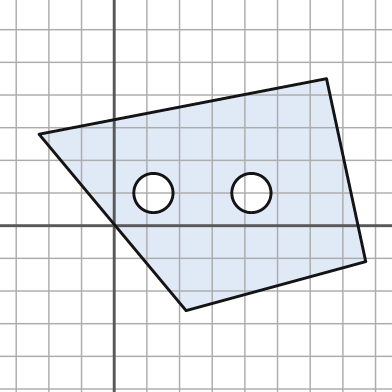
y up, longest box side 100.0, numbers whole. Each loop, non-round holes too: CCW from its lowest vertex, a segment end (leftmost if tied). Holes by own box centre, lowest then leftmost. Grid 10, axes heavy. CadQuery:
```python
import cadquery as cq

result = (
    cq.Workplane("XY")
    .moveTo(22.0, -26.0)
    .lineTo(77.0, -11.0)
    .lineTo(65.0, 45.0)
    .lineTo(-23.0, 28.0)
    .close()
    .moveTo(12.0, 10.0)
    .circle(6.0)
    .moveTo(42.0, 10.0)
    .circle(6.0)
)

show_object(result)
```